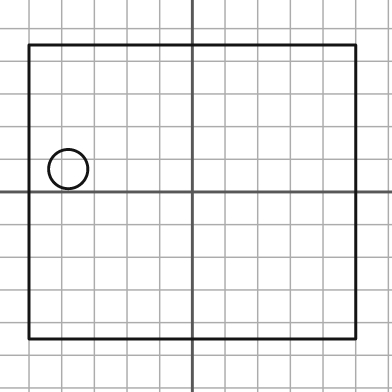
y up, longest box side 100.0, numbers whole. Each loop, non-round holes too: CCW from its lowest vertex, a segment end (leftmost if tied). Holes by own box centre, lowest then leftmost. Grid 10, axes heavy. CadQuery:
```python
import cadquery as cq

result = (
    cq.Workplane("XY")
    .moveTo(-50.0, -45.0)
    .lineTo(50.0, -45.0)
    .lineTo(50.0, 45.0)
    .lineTo(-50.0, 45.0)
    .close()
    .moveTo(-38.0, 7.0)
    .circle(6.0)
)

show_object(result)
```